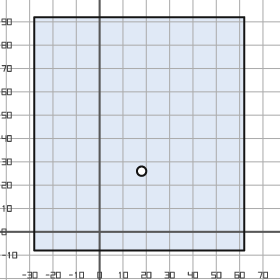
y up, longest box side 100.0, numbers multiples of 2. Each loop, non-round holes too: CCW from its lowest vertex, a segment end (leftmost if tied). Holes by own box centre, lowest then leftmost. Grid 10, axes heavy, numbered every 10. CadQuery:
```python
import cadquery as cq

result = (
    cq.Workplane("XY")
    .moveTo(-28.0, -8.0)
    .lineTo(62.0, -8.0)
    .lineTo(62.0, 92.0)
    .lineTo(-28.0, 92.0)
    .close()
    .moveTo(18.0, 26.0)
    .circle(2.0)
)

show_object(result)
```